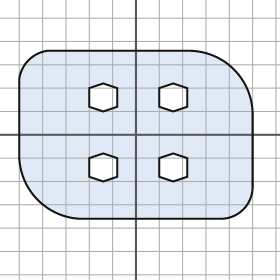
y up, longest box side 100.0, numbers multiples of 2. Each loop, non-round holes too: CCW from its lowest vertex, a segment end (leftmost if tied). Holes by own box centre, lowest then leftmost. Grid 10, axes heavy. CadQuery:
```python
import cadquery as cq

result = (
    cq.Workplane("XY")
    .moveTo(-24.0, -36.0)
    .lineTo(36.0, -36.0)
    .threePointArc((46.0, -32.0), (50.0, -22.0))
    .lineTo(50.0, 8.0)
    .threePointArc((42.0, 28.0), (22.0, 36.0))
    .lineTo(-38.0, 36.0)
    .threePointArc((-46.0, 32.0), (-50.0, 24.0))
    .lineTo(-50.0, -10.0)
    .threePointArc((-42.0, -28.0), (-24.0, -36.0))
    .close()
    .moveTo(-14.0, -20.0)
    .lineTo(-8.0, -18.0)
    .lineTo(-8.0, -10.0)
    .lineTo(-14.0, -8.0)
    .lineTo(-20.0, -10.0)
    .lineTo(-20.0, -18.0)
    .close()
    .moveTo(16.0, -20.0)
    .lineTo(22.0, -18.0)
    .lineTo(22.0, -10.0)
    .lineTo(16.0, -8.0)
    .lineTo(10.0, -10.0)
    .lineTo(10.0, -18.0)
    .close()
    .moveTo(-14.0, 10.0)
    .lineTo(-8.0, 12.0)
    .lineTo(-8.0, 20.0)
    .lineTo(-14.0, 22.0)
    .lineTo(-20.0, 20.0)
    .lineTo(-20.0, 12.0)
    .close()
    .moveTo(16.0, 10.0)
    .lineTo(22.0, 12.0)
    .lineTo(22.0, 20.0)
    .lineTo(16.0, 22.0)
    .lineTo(10.0, 20.0)
    .lineTo(10.0, 12.0)
    .close()
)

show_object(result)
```